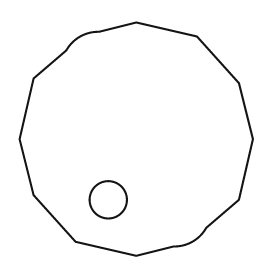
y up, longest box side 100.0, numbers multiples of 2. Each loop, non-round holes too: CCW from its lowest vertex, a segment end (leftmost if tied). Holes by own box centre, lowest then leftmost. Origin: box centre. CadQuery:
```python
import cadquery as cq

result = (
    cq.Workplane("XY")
    .moveTo(0.0, -50.0)
    .lineTo(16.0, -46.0)
    .threePointArc((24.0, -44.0), (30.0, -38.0))
    .lineTo(44.0, -26.0)
    .lineTo(50.0, 0.0)
    .lineTo(44.0, 24.0)
    .lineTo(26.0, 44.0)
    .lineTo(0.0, 50.0)
    .lineTo(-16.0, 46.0)
    .threePointArc((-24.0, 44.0), (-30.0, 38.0))
    .lineTo(-44.0, 26.0)
    .lineTo(-50.0, 0.0)
    .lineTo(-44.0, -24.0)
    .lineTo(-26.0, -44.0)
    .close()
    .moveTo(-12.0, -26.0)
    .circle(8.0)
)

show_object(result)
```